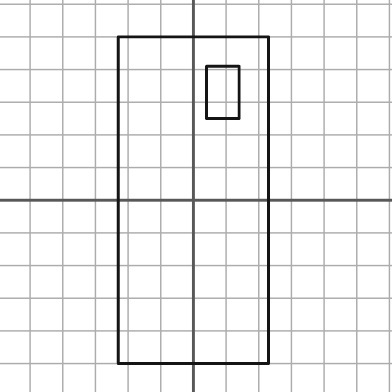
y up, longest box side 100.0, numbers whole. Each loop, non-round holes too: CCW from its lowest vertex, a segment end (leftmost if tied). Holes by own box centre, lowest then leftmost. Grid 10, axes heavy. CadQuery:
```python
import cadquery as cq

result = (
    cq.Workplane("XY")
    .moveTo(-23.0, -50.0)
    .lineTo(23.0, -50.0)
    .lineTo(23.0, 50.0)
    .lineTo(-23.0, 50.0)
    .close()
    .moveTo(4.0, 25.0)
    .lineTo(14.0, 25.0)
    .lineTo(14.0, 41.0)
    .lineTo(4.0, 41.0)
    .close()
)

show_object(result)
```